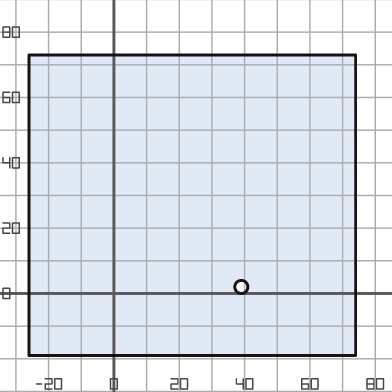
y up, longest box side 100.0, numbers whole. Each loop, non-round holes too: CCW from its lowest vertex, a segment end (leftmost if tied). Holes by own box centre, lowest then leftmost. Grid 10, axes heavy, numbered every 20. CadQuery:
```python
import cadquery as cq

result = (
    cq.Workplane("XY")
    .moveTo(-26.0, -19.0)
    .lineTo(74.0, -19.0)
    .lineTo(74.0, 73.0)
    .lineTo(-26.0, 73.0)
    .close()
    .moveTo(39.0, 2.0)
    .circle(2.0)
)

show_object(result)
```